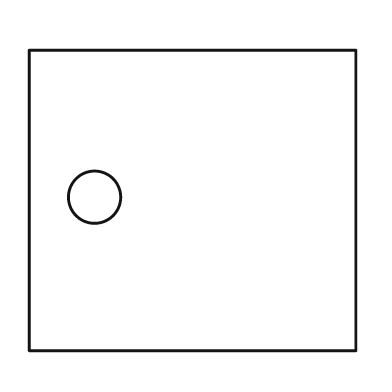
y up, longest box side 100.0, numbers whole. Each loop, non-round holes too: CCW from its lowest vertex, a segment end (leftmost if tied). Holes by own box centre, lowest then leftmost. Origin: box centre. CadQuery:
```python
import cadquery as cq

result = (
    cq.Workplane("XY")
    .moveTo(-50.0, -46.0)
    .lineTo(50.0, -46.0)
    .lineTo(50.0, 46.0)
    .lineTo(-50.0, 46.0)
    .close()
    .moveTo(-30.0, 1.0)
    .circle(8.0)
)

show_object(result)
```